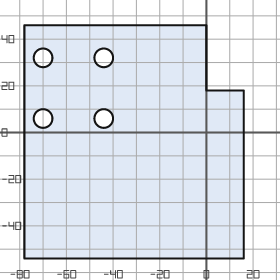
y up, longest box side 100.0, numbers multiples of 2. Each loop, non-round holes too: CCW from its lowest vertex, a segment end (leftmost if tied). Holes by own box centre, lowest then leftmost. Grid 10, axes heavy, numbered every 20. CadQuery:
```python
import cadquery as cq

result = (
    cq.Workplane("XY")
    .moveTo(-78.0, -54.0)
    .lineTo(16.0, -54.0)
    .lineTo(16.0, 18.0)
    .lineTo(0.0, 18.0)
    .lineTo(0.0, 46.0)
    .lineTo(-78.0, 46.0)
    .close()
    .moveTo(-70.0, 6.0)
    .circle(4.0)
    .moveTo(-44.0, 6.0)
    .circle(4.0)
    .moveTo(-70.0, 32.0)
    .circle(4.0)
    .moveTo(-44.0, 32.0)
    .circle(4.0)
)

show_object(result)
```